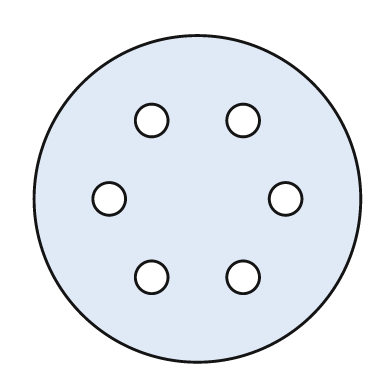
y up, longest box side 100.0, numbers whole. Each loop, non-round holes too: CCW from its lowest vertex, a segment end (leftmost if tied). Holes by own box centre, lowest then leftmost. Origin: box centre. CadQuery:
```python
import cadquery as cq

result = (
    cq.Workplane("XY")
    .moveTo(0.0, 0.0)
    .circle(50.0)
    .moveTo(-14.0, -24.0)
    .circle(5.0)
    .moveTo(14.0, -24.0)
    .circle(5.0)
    .moveTo(-27.0, 0.0)
    .circle(5.0)
    .moveTo(27.0, 0.0)
    .circle(5.0)
    .moveTo(-14.0, 24.0)
    .circle(5.0)
    .moveTo(14.0, 24.0)
    .circle(5.0)
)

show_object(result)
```